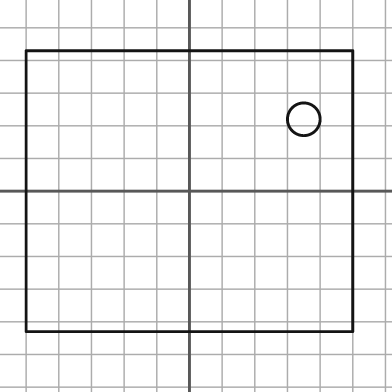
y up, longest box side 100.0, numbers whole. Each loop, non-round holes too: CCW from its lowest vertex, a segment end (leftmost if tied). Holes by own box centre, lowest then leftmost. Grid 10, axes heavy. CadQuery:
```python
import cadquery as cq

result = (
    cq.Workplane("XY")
    .moveTo(-50.0, -43.0)
    .lineTo(50.0, -43.0)
    .lineTo(50.0, 43.0)
    .lineTo(-50.0, 43.0)
    .close()
    .moveTo(35.0, 22.0)
    .circle(5.0)
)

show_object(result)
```